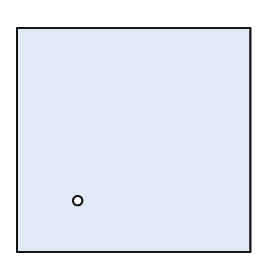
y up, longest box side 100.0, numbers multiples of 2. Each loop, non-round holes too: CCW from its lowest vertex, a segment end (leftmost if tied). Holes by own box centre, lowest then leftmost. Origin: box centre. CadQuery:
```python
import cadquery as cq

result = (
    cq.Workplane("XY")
    .moveTo(-50.0, -48.0)
    .lineTo(50.0, -48.0)
    .lineTo(50.0, 48.0)
    .lineTo(-50.0, 48.0)
    .close()
    .moveTo(-24.0, -26.0)
    .circle(2.0)
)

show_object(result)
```